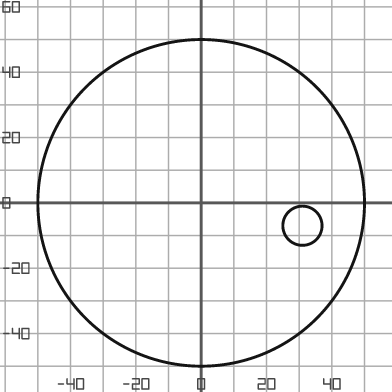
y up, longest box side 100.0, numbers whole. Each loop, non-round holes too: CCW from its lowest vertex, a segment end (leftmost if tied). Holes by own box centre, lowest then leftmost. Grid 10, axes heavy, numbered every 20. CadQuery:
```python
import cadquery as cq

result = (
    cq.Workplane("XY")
    .moveTo(0.0, 0.0)
    .circle(50.0)
    .moveTo(31.0, -7.0)
    .circle(6.0)
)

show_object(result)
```